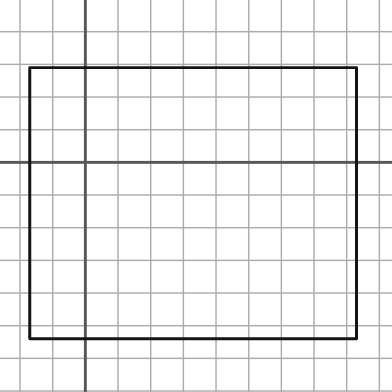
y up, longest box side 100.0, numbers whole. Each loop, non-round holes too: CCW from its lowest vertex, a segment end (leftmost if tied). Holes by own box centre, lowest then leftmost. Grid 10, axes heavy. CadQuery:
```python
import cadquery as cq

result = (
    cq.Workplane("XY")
    .moveTo(-17.0, -54.0)
    .lineTo(83.0, -54.0)
    .lineTo(83.0, 29.0)
    .lineTo(-17.0, 29.0)
    .close()
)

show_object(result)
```